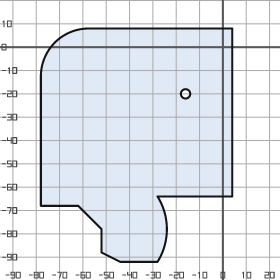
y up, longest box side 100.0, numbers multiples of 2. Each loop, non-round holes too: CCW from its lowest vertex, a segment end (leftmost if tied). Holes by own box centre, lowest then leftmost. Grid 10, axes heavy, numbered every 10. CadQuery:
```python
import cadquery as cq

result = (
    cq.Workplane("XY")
    .moveTo(-44.0, -92.0)
    .lineTo(-28.0, -92.0)
    .threePointArc((-24.0, -78.0), (-28.0, -64.0))
    .lineTo(4.0, -64.0)
    .lineTo(4.0, 8.0)
    .lineTo(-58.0, 8.0)
    .threePointArc((-72.0, 2.0), (-78.0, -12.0))
    .lineTo(-78.0, -68.0)
    .lineTo(-62.0, -68.0)
    .lineTo(-52.0, -78.0)
    .lineTo(-52.0, -88.0)
    .close()
    .moveTo(-16.0, -20.0)
    .circle(2.0)
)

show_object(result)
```